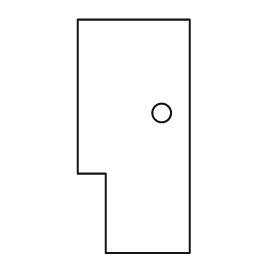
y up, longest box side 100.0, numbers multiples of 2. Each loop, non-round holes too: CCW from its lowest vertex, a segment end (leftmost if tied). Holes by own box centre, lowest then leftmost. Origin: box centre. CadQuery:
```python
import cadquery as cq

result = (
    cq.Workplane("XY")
    .moveTo(-12.0, -50.0)
    .lineTo(24.0, -50.0)
    .lineTo(24.0, 50.0)
    .lineTo(-24.0, 50.0)
    .lineTo(-24.0, -16.0)
    .lineTo(-12.0, -16.0)
    .close()
    .moveTo(12.0, 10.0)
    .circle(4.0)
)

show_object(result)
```